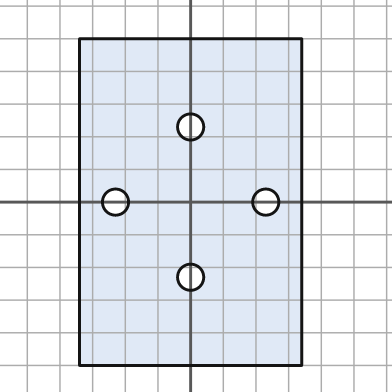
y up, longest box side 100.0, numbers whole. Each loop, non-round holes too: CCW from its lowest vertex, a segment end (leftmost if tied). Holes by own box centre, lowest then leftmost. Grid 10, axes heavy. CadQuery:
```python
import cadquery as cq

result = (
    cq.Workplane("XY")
    .moveTo(-34.0, -50.0)
    .lineTo(34.0, -50.0)
    .lineTo(34.0, 50.0)
    .lineTo(-34.0, 50.0)
    .close()
    .moveTo(0.0, -23.0)
    .circle(4.0)
    .moveTo(-23.0, 0.0)
    .circle(4.0)
    .moveTo(23.0, 0.0)
    .circle(4.0)
    .moveTo(0.0, 23.0)
    .circle(4.0)
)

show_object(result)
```